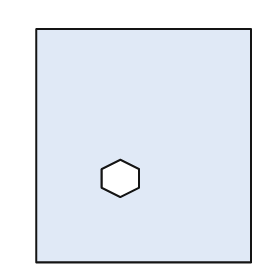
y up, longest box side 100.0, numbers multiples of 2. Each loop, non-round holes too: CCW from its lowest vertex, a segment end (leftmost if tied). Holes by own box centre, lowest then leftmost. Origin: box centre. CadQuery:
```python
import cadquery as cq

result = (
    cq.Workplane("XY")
    .moveTo(-46.0, -50.0)
    .lineTo(46.0, -50.0)
    .lineTo(46.0, 50.0)
    .lineTo(-46.0, 50.0)
    .close()
    .moveTo(-10.0, -22.0)
    .lineTo(-2.0, -18.0)
    .lineTo(-2.0, -10.0)
    .lineTo(-10.0, -6.0)
    .lineTo(-18.0, -10.0)
    .lineTo(-18.0, -18.0)
    .close()
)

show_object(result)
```